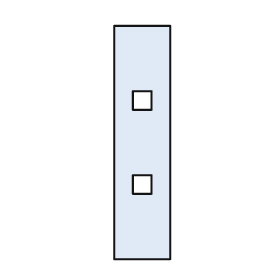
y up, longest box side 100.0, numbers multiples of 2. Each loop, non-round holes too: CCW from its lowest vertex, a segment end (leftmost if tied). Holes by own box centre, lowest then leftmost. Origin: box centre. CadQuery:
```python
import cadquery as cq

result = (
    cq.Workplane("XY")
    .moveTo(-12.0, -50.0)
    .lineTo(12.0, -50.0)
    .lineTo(12.0, 50.0)
    .lineTo(-12.0, 50.0)
    .close()
    .moveTo(-4.0, -22.0)
    .lineTo(4.0, -22.0)
    .lineTo(4.0, -14.0)
    .lineTo(-4.0, -14.0)
    .close()
    .moveTo(-4.0, 14.0)
    .lineTo(4.0, 14.0)
    .lineTo(4.0, 22.0)
    .lineTo(-4.0, 22.0)
    .close()
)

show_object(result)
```